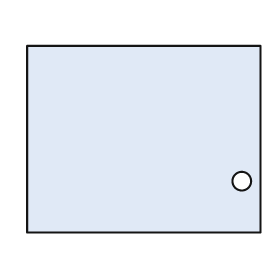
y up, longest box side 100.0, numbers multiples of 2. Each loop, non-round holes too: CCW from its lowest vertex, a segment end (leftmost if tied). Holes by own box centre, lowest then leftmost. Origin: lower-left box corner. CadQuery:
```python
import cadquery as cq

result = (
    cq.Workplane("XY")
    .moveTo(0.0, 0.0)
    .lineTo(100.0, 0.0)
    .lineTo(100.0, 80.0)
    .lineTo(0.0, 80.0)
    .close()
    .moveTo(92.0, 22.0)
    .circle(4.0)
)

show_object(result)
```